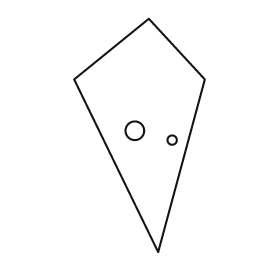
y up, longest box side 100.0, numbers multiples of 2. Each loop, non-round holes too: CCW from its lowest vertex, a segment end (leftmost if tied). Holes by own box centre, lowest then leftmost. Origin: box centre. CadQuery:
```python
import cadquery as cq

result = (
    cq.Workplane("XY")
    .moveTo(8.0, -50.0)
    .lineTo(28.0, 24.0)
    .lineTo(4.0, 50.0)
    .lineTo(-28.0, 24.0)
    .close()
    .moveTo(14.0, -2.0)
    .circle(2.0)
    .moveTo(-2.0, 2.0)
    .circle(4.0)
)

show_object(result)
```